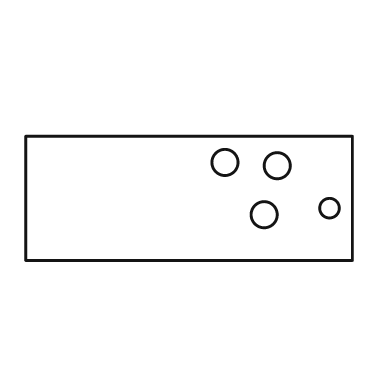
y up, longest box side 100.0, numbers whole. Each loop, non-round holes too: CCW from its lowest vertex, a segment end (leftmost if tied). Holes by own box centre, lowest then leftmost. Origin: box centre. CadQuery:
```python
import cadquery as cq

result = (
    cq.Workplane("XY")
    .moveTo(-50.0, -19.0)
    .lineTo(50.0, -19.0)
    .lineTo(50.0, 19.0)
    .lineTo(-50.0, 19.0)
    .close()
    .moveTo(23.0, -5.0)
    .circle(4.0)
    .moveTo(43.0, -3.0)
    .circle(3.0)
    .moveTo(27.0, 10.0)
    .circle(4.0)
    .moveTo(11.0, 11.0)
    .circle(4.0)
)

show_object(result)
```